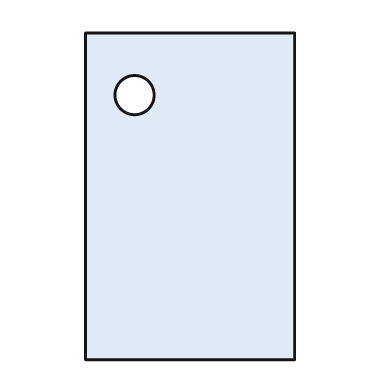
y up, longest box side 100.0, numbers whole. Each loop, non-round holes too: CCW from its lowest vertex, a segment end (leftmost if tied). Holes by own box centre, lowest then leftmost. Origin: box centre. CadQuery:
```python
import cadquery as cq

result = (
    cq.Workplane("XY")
    .moveTo(-32.0, -50.0)
    .lineTo(32.0, -50.0)
    .lineTo(32.0, 50.0)
    .lineTo(-32.0, 50.0)
    .close()
    .moveTo(-17.0, 31.0)
    .circle(6.0)
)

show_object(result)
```